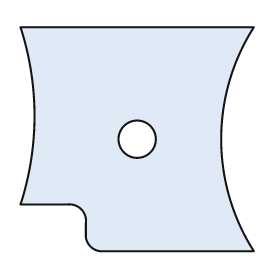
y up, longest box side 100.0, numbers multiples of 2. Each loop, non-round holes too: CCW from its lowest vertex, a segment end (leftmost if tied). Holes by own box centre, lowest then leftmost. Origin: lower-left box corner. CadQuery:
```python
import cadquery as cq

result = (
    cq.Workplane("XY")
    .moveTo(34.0, 0.0)
    .lineTo(100.0, 0.0)
    .threePointArc((86.0, 48.0), (100.0, 96.0))
    .lineTo(0.0, 96.0)
    .threePointArc((6.0, 58.0), (0.0, 20.0))
    .lineTo(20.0, 20.0)
    .threePointArc((26.0, 18.0), (28.0, 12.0))
    .lineTo(28.0, 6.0)
    .threePointArc((30.0, 2.0), (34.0, 0.0))
    .close()
    .moveTo(50.0, 48.0)
    .circle(8.0)
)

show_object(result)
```